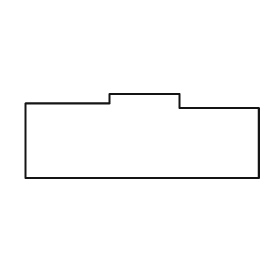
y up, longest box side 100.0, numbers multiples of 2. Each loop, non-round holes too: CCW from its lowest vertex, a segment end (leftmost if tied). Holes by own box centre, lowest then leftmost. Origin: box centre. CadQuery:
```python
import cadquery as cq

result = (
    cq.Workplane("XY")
    .moveTo(-50.0, -18.0)
    .lineTo(50.0, -18.0)
    .lineTo(50.0, 12.0)
    .lineTo(16.0, 12.0)
    .lineTo(16.0, 18.0)
    .lineTo(-14.0, 18.0)
    .lineTo(-14.0, 14.0)
    .lineTo(-50.0, 14.0)
    .close()
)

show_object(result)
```